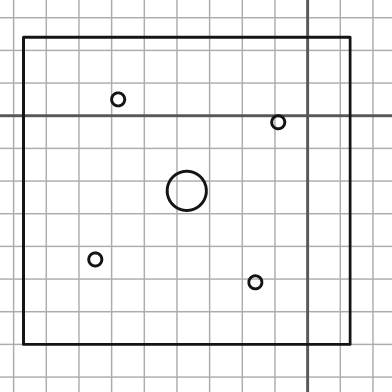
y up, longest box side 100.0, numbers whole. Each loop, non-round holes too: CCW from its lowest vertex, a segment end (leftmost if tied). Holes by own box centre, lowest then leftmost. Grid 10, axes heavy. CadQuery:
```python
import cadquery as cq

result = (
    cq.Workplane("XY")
    .moveTo(-87.0, -70.0)
    .lineTo(13.0, -70.0)
    .lineTo(13.0, 24.0)
    .lineTo(-87.0, 24.0)
    .close()
    .moveTo(-16.0, -51.0)
    .circle(2.0)
    .moveTo(-65.0, -44.0)
    .circle(2.0)
    .moveTo(-37.0, -23.0)
    .circle(6.0)
    .moveTo(-9.0, -2.0)
    .circle(2.0)
    .moveTo(-58.0, 5.0)
    .circle(2.0)
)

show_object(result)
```